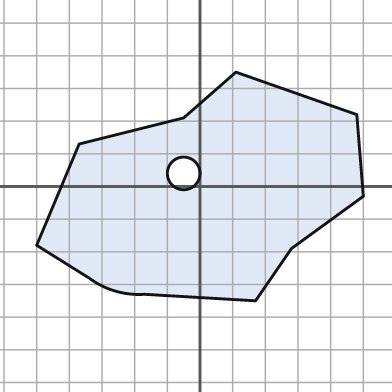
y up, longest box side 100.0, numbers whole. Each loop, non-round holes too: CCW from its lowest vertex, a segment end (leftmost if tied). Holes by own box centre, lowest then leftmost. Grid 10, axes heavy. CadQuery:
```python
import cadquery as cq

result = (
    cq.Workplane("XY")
    .moveTo(17.0, -35.0)
    .lineTo(28.0, -19.0)
    .lineTo(50.0, -3.0)
    .lineTo(48.0, 22.0)
    .lineTo(11.0, 35.0)
    .lineTo(-5.0, 21.0)
    .lineTo(-37.0, 13.0)
    .lineTo(-50.0, -18.0)
    .lineTo(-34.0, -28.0)
    .threePointArc((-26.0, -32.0), (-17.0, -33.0))
    .close()
    .moveTo(-5.0, 4.0)
    .circle(5.0)
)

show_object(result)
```